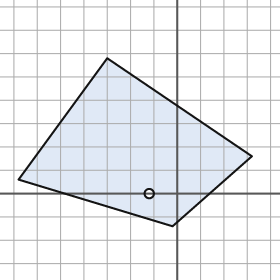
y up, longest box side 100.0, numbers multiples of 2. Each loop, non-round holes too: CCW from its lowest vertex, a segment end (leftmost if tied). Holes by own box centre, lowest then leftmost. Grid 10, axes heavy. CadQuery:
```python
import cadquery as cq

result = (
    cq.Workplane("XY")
    .moveTo(-2.0, -14.0)
    .lineTo(32.0, 16.0)
    .lineTo(-30.0, 58.0)
    .lineTo(-68.0, 6.0)
    .close()
    .moveTo(-12.0, 0.0)
    .circle(2.0)
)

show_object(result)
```